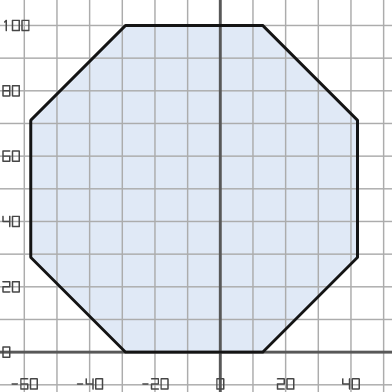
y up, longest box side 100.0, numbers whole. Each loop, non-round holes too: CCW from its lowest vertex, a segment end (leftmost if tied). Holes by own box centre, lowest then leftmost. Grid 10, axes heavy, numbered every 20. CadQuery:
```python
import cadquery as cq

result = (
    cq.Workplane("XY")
    .moveTo(-29.0, 0.0)
    .lineTo(13.0, 0.0)
    .lineTo(42.0, 29.0)
    .lineTo(42.0, 71.0)
    .lineTo(13.0, 100.0)
    .lineTo(-29.0, 100.0)
    .lineTo(-58.0, 71.0)
    .lineTo(-58.0, 29.0)
    .close()
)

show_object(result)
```